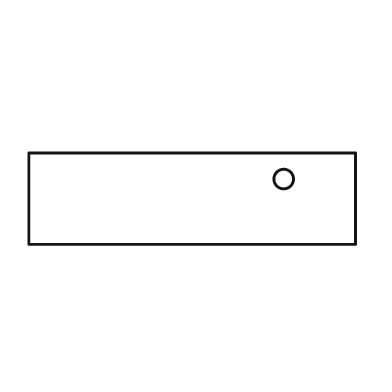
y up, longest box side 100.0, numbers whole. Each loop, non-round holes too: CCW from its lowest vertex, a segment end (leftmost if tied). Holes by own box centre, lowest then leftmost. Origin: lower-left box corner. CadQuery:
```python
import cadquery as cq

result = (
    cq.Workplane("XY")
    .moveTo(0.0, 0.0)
    .lineTo(100.0, 0.0)
    .lineTo(100.0, 28.0)
    .lineTo(0.0, 28.0)
    .close()
    .moveTo(78.0, 20.0)
    .circle(3.0)
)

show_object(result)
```